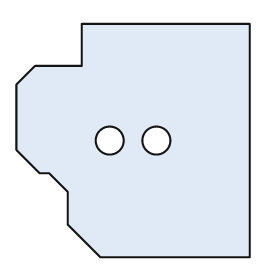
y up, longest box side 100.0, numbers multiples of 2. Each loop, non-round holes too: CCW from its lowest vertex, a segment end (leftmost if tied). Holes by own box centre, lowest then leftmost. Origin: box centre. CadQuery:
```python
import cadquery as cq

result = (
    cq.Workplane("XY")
    .moveTo(-14.0, -50.0)
    .lineTo(50.0, -50.0)
    .lineTo(50.0, 50.0)
    .lineTo(-22.0, 50.0)
    .lineTo(-22.0, 32.0)
    .lineTo(-42.0, 32.0)
    .lineTo(-50.0, 24.0)
    .lineTo(-50.0, -4.0)
    .lineTo(-40.0, -14.0)
    .lineTo(-36.0, -14.0)
    .lineTo(-28.0, -22.0)
    .lineTo(-28.0, -36.0)
    .close()
    .moveTo(-10.0, 0.0)
    .circle(6.0)
    .moveTo(10.0, 0.0)
    .circle(6.0)
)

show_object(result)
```